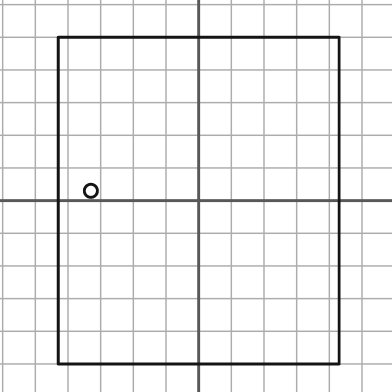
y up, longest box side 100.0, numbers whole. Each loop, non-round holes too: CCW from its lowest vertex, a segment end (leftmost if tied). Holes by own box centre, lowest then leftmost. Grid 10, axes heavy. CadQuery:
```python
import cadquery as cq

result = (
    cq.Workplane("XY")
    .moveTo(-43.0, -50.0)
    .lineTo(43.0, -50.0)
    .lineTo(43.0, 50.0)
    .lineTo(-43.0, 50.0)
    .close()
    .moveTo(-33.0, 3.0)
    .circle(2.0)
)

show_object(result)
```